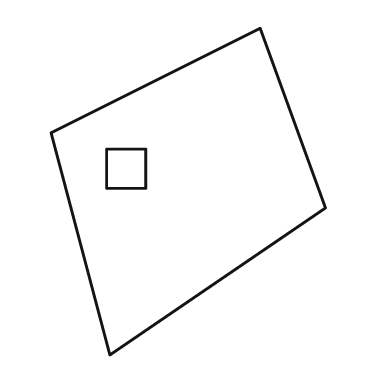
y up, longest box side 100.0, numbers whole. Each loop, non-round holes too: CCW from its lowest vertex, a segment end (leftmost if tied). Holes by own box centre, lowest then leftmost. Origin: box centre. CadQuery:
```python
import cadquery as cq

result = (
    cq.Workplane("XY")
    .moveTo(-24.0, -50.0)
    .lineTo(42.0, -5.0)
    .lineTo(22.0, 50.0)
    .lineTo(-42.0, 18.0)
    .close()
    .moveTo(-25.0, 1.0)
    .lineTo(-13.0, 1.0)
    .lineTo(-13.0, 13.0)
    .lineTo(-25.0, 13.0)
    .close()
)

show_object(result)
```